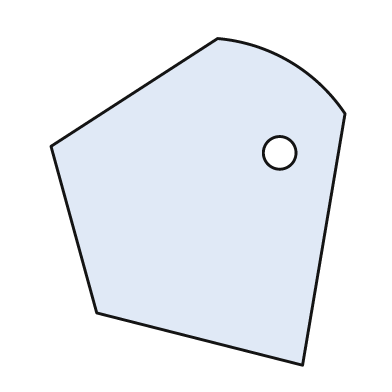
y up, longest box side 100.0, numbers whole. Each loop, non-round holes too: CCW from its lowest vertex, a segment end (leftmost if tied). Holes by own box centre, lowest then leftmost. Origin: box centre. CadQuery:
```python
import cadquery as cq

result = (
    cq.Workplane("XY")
    .moveTo(32.0, -50.0)
    .lineTo(45.0, 27.0)
    .threePointArc((28.0, 43.0), (6.0, 50.0))
    .lineTo(-45.0, 17.0)
    .lineTo(-31.0, -34.0)
    .close()
    .moveTo(25.0, 15.0)
    .circle(5.0)
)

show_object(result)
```